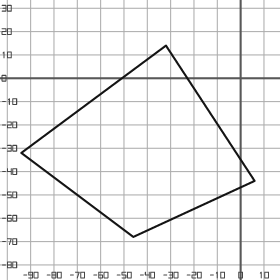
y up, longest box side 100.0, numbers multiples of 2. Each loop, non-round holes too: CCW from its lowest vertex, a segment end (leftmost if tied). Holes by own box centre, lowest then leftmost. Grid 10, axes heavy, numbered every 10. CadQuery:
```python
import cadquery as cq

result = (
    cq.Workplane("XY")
    .moveTo(-46.0, -68.0)
    .lineTo(6.0, -44.0)
    .lineTo(-32.0, 14.0)
    .lineTo(-94.0, -32.0)
    .close()
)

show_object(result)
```